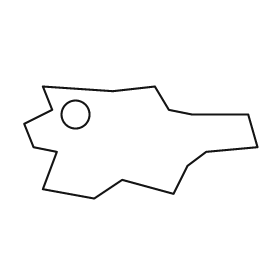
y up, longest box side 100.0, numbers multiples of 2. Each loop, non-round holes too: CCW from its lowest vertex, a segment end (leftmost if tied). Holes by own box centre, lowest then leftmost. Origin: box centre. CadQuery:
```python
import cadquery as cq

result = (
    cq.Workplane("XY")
    .moveTo(-20.0, -24.0)
    .lineTo(-8.0, -16.0)
    .lineTo(14.0, -22.0)
    .lineTo(20.0, -10.0)
    .lineTo(28.0, -4.0)
    .lineTo(50.0, -2.0)
    .lineTo(46.0, 12.0)
    .lineTo(22.0, 12.0)
    .lineTo(12.0, 14.0)
    .lineTo(6.0, 24.0)
    .lineTo(-12.0, 22.0)
    .lineTo(-42.0, 24.0)
    .lineTo(-38.0, 14.0)
    .lineTo(-50.0, 8.0)
    .lineTo(-46.0, -2.0)
    .lineTo(-36.0, -4.0)
    .lineTo(-42.0, -20.0)
    .close()
    .moveTo(-28.0, 12.0)
    .circle(6.0)
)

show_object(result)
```